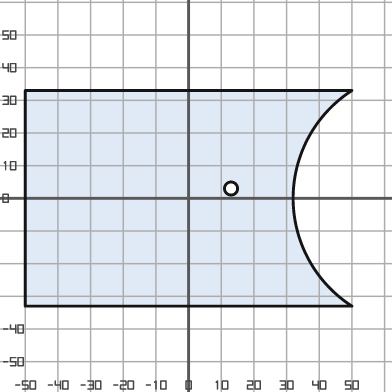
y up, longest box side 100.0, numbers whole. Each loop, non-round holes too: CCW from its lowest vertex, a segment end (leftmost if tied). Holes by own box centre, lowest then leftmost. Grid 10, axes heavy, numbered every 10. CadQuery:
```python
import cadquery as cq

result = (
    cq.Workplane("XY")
    .moveTo(-50.0, -33.0)
    .lineTo(50.0, -33.0)
    .threePointArc((32.0, 0.0), (50.0, 33.0))
    .lineTo(-50.0, 33.0)
    .close()
    .moveTo(13.0, 3.0)
    .circle(2.0)
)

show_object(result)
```